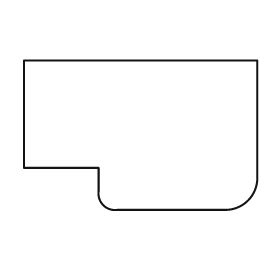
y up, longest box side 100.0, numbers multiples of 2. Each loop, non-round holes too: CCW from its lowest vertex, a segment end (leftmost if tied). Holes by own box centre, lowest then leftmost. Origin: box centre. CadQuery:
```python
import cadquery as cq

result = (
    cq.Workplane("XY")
    .moveTo(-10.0, -32.0)
    .lineTo(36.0, -32.0)
    .threePointArc((46.0, -28.0), (50.0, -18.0))
    .lineTo(50.0, 32.0)
    .lineTo(-50.0, 32.0)
    .lineTo(-50.0, -14.0)
    .lineTo(-18.0, -14.0)
    .lineTo(-18.0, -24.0)
    .threePointArc((-16.0, -30.0), (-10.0, -32.0))
    .close()
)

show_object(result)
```